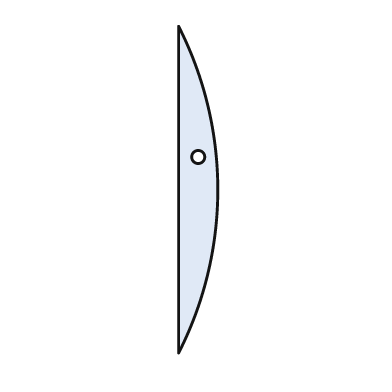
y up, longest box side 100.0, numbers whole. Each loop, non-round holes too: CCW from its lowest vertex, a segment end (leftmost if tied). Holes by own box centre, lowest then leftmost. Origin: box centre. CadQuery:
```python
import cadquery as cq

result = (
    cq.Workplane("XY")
    .moveTo(-6.0, -50.0)
    .threePointArc((6.0, 0.0), (-6.0, 50.0))
    .close()
    .moveTo(0.0, 10.0)
    .circle(2.0)
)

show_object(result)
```